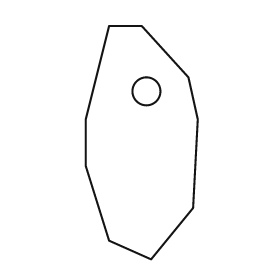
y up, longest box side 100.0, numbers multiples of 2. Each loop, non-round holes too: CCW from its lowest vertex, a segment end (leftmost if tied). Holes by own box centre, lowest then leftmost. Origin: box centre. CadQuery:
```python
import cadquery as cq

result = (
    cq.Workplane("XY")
    .moveTo(4.0, -50.0)
    .lineTo(22.0, -28.0)
    .lineTo(24.0, 10.0)
    .lineTo(20.0, 28.0)
    .lineTo(0.0, 50.0)
    .lineTo(-14.0, 50.0)
    .lineTo(-24.0, 10.0)
    .lineTo(-24.0, -10.0)
    .lineTo(-14.0, -42.0)
    .close()
    .moveTo(2.0, 22.0)
    .circle(6.0)
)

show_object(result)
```